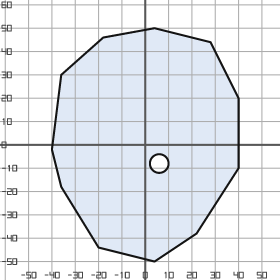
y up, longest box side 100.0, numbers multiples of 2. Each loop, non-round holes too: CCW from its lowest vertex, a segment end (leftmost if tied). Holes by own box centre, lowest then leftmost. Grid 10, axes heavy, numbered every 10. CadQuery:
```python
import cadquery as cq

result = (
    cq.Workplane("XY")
    .moveTo(4.0, -50.0)
    .lineTo(22.0, -38.0)
    .lineTo(40.0, -10.0)
    .lineTo(40.0, 20.0)
    .lineTo(28.0, 44.0)
    .lineTo(4.0, 50.0)
    .lineTo(-18.0, 46.0)
    .lineTo(-36.0, 30.0)
    .lineTo(-40.0, -2.0)
    .lineTo(-36.0, -18.0)
    .lineTo(-20.0, -44.0)
    .close()
    .moveTo(6.0, -8.0)
    .circle(4.0)
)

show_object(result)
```